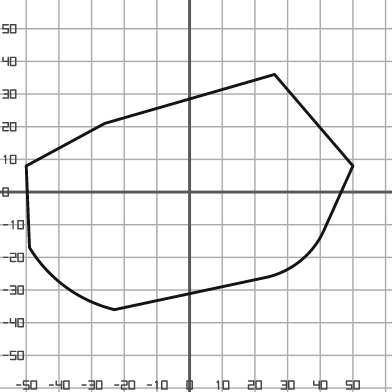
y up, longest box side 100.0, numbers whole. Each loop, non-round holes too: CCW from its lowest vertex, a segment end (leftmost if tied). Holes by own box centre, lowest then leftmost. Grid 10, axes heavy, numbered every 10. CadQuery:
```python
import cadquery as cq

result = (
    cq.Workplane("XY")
    .moveTo(-23.0, -36.0)
    .lineTo(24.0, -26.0)
    .threePointArc((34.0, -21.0), (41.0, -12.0))
    .lineTo(50.0, 8.0)
    .lineTo(26.0, 36.0)
    .lineTo(-26.0, 21.0)
    .lineTo(-50.0, 8.0)
    .lineTo(-49.0, -17.0)
    .threePointArc((-38.0, -29.0), (-23.0, -36.0))
    .close()
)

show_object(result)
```